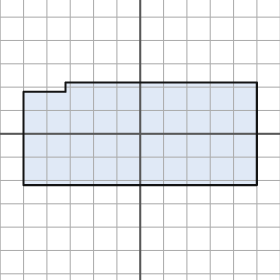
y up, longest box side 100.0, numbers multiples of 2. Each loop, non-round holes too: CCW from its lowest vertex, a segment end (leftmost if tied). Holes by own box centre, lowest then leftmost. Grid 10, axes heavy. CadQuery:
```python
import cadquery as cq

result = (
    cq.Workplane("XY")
    .moveTo(-50.0, -22.0)
    .lineTo(50.0, -22.0)
    .lineTo(50.0, 22.0)
    .lineTo(-32.0, 22.0)
    .lineTo(-32.0, 18.0)
    .lineTo(-50.0, 18.0)
    .close()
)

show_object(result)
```